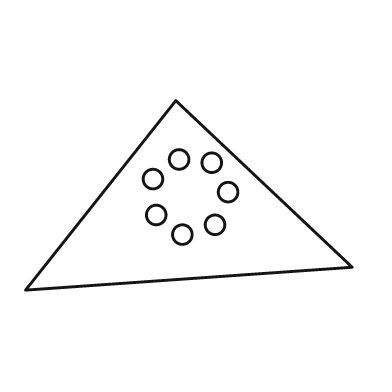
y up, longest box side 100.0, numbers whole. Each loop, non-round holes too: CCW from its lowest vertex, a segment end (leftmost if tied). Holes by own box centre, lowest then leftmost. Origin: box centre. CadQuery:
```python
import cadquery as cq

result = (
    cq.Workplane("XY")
    .moveTo(-50.0, -29.0)
    .lineTo(50.0, -22.0)
    .lineTo(-4.0, 29.0)
    .close()
    .moveTo(-2.0, -12.0)
    .circle(3.0)
    .moveTo(8.0, -9.0)
    .circle(3.0)
    .moveTo(-10.0, -6.0)
    .circle(3.0)
    .moveTo(12.0, 1.0)
    .circle(3.0)
    .moveTo(-11.0, 5.0)
    .circle(3.0)
    .moveTo(7.0, 10.0)
    .circle(3.0)
    .moveTo(-3.0, 11.0)
    .circle(3.0)
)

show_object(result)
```